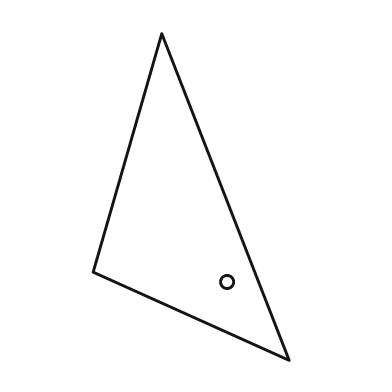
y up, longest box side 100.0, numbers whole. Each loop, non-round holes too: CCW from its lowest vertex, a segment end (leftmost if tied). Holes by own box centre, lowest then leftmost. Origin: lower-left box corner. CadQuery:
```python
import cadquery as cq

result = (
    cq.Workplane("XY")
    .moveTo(60.0, 0.0)
    .lineTo(21.0, 100.0)
    .lineTo(0.0, 27.0)
    .close()
    .moveTo(41.0, 24.0)
    .circle(2.0)
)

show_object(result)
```